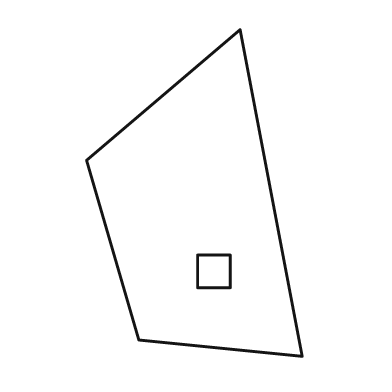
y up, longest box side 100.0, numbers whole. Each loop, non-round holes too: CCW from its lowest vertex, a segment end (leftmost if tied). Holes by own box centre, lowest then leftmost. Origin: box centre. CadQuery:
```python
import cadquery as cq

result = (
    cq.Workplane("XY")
    .moveTo(33.0, -50.0)
    .lineTo(14.0, 50.0)
    .lineTo(-33.0, 10.0)
    .lineTo(-17.0, -45.0)
    .close()
    .moveTo(1.0, -29.0)
    .lineTo(11.0, -29.0)
    .lineTo(11.0, -19.0)
    .lineTo(1.0, -19.0)
    .close()
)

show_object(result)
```